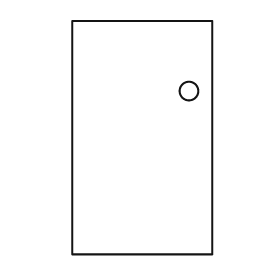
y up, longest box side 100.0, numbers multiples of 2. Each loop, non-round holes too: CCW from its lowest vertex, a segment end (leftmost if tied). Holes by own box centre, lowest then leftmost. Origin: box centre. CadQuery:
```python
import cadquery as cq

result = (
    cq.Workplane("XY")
    .moveTo(-30.0, -50.0)
    .lineTo(30.0, -50.0)
    .lineTo(30.0, 50.0)
    .lineTo(-30.0, 50.0)
    .close()
    .moveTo(20.0, 20.0)
    .circle(4.0)
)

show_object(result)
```